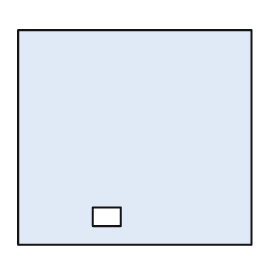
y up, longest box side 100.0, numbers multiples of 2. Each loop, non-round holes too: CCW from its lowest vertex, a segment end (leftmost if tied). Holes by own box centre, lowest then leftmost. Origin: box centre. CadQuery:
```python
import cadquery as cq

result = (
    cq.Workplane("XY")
    .moveTo(-50.0, -46.0)
    .lineTo(50.0, -46.0)
    .lineTo(50.0, 46.0)
    .lineTo(-50.0, 46.0)
    .close()
    .moveTo(-18.0, -38.0)
    .lineTo(-6.0, -38.0)
    .lineTo(-6.0, -30.0)
    .lineTo(-18.0, -30.0)
    .close()
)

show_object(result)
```